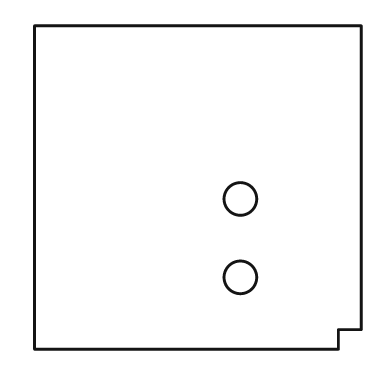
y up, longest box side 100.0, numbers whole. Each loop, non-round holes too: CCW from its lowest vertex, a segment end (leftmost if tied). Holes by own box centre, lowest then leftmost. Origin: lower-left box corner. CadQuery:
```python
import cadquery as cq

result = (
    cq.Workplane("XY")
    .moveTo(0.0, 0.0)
    .lineTo(93.0, 0.0)
    .lineTo(93.0, 6.0)
    .lineTo(100.0, 6.0)
    .lineTo(100.0, 99.0)
    .lineTo(0.0, 99.0)
    .close()
    .moveTo(63.0, 22.0)
    .circle(5.0)
    .moveTo(63.0, 46.0)
    .circle(5.0)
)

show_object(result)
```